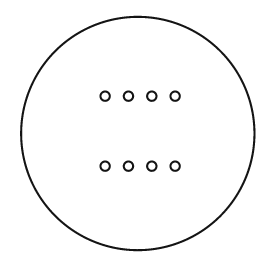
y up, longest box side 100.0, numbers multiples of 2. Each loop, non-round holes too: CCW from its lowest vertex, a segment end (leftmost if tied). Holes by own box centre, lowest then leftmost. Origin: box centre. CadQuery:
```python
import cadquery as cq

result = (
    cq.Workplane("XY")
    .moveTo(0.0, 0.0)
    .circle(50.0)
    .moveTo(-14.0, -14.0)
    .circle(2.0)
    .moveTo(-4.0, -14.0)
    .circle(2.0)
    .moveTo(6.0, -14.0)
    .circle(2.0)
    .moveTo(16.0, -14.0)
    .circle(2.0)
    .moveTo(-14.0, 16.0)
    .circle(2.0)
    .moveTo(-4.0, 16.0)
    .circle(2.0)
    .moveTo(6.0, 16.0)
    .circle(2.0)
    .moveTo(16.0, 16.0)
    .circle(2.0)
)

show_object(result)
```